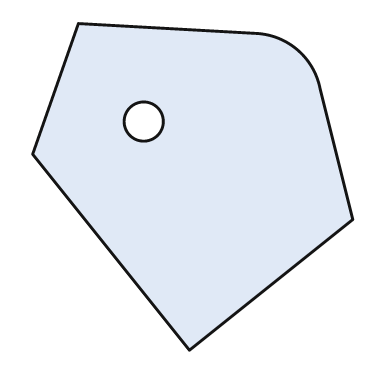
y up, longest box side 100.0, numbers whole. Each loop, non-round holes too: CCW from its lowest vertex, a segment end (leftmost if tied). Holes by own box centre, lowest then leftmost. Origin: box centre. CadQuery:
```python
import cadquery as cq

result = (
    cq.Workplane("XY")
    .moveTo(-1.0, -50.0)
    .lineTo(49.0, -10.0)
    .lineTo(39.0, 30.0)
    .threePointArc((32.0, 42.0), (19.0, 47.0))
    .lineTo(-35.0, 50.0)
    .lineTo(-49.0, 10.0)
    .close()
    .moveTo(-15.0, 20.0)
    .circle(6.0)
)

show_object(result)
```